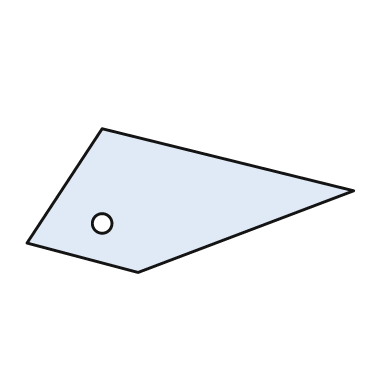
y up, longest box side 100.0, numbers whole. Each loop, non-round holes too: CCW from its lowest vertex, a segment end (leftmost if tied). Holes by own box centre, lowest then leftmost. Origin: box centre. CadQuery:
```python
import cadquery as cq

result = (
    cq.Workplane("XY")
    .moveTo(-16.0, -22.0)
    .lineTo(50.0, 3.0)
    .lineTo(-27.0, 22.0)
    .lineTo(-50.0, -13.0)
    .close()
    .moveTo(-27.0, -7.0)
    .circle(3.0)
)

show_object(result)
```